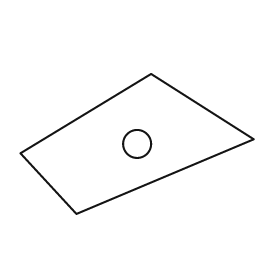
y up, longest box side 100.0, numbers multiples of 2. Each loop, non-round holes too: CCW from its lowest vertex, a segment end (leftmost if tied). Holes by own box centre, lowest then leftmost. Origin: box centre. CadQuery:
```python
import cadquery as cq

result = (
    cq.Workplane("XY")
    .moveTo(-26.0, -30.0)
    .lineTo(50.0, 2.0)
    .lineTo(6.0, 30.0)
    .lineTo(-50.0, -4.0)
    .close()
    .moveTo(0.0, 0.0)
    .circle(6.0)
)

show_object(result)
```